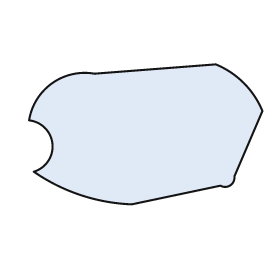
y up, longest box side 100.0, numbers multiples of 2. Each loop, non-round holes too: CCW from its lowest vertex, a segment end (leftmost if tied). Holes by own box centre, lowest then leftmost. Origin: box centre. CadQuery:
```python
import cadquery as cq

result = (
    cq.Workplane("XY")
    .moveTo(-6.0, -30.0)
    .lineTo(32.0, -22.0)
    .threePointArc((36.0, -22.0), (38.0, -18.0))
    .lineTo(50.0, 10.0)
    .threePointArc((42.0, 22.0), (30.0, 30.0))
    .lineTo(-22.0, 26.0)
    .threePointArc((-40.0, 22.0), (-50.0, 6.0))
    .threePointArc((-40.0, -4.0), (-48.0, -16.0))
    .threePointArc((-28.0, -26.0), (-6.0, -30.0))
    .close()
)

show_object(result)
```